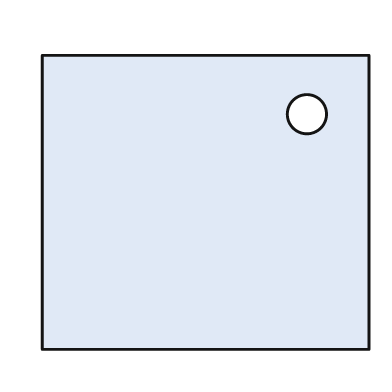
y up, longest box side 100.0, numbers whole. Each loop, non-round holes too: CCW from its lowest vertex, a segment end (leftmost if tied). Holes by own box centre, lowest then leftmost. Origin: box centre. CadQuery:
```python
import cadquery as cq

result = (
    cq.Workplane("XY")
    .moveTo(-50.0, -45.0)
    .lineTo(50.0, -45.0)
    .lineTo(50.0, 45.0)
    .lineTo(-50.0, 45.0)
    .close()
    .moveTo(31.0, 27.0)
    .circle(6.0)
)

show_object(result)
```